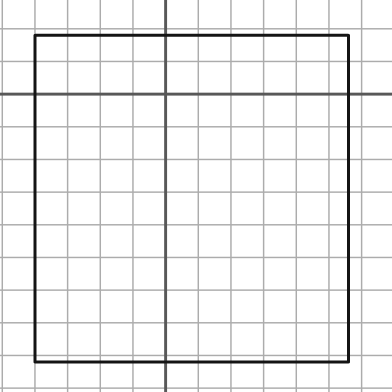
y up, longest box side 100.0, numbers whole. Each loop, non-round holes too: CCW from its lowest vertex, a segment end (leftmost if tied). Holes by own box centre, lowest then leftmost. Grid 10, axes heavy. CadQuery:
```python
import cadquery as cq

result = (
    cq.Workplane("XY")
    .moveTo(-40.0, -82.0)
    .lineTo(56.0, -82.0)
    .lineTo(56.0, 18.0)
    .lineTo(-40.0, 18.0)
    .close()
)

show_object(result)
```